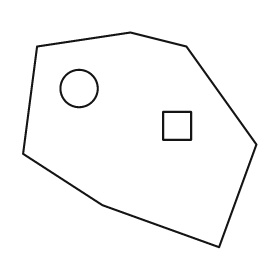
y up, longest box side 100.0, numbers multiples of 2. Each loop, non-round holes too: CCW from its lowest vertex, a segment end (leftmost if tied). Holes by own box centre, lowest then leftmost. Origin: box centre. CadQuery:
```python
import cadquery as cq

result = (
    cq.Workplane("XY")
    .moveTo(34.0, -46.0)
    .lineTo(50.0, -2.0)
    .lineTo(20.0, 40.0)
    .lineTo(-4.0, 46.0)
    .lineTo(-44.0, 40.0)
    .lineTo(-50.0, -6.0)
    .lineTo(-16.0, -28.0)
    .close()
    .moveTo(10.0, 0.0)
    .lineTo(22.0, 0.0)
    .lineTo(22.0, 12.0)
    .lineTo(10.0, 12.0)
    .close()
    .moveTo(-26.0, 22.0)
    .circle(8.0)
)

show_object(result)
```